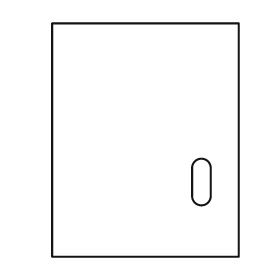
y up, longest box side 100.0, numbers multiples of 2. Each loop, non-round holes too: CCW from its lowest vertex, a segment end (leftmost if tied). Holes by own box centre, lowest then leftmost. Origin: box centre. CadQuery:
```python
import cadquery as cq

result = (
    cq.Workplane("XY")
    .moveTo(-40.0, -50.0)
    .lineTo(40.0, -50.0)
    .lineTo(40.0, 50.0)
    .lineTo(-40.0, 50.0)
    .close()
    .moveTo(20.0, -24.0)
    .threePointArc((24.0, -28.0), (28.0, -24.0))
    .lineTo(28.0, -12.0)
    .threePointArc((24.0, -8.0), (20.0, -12.0))
    .close()
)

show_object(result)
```